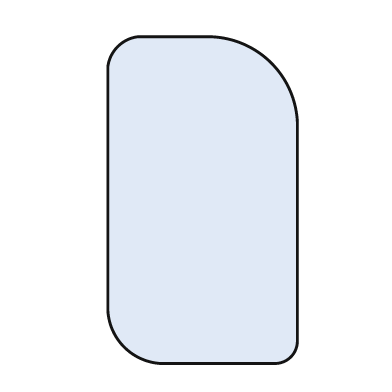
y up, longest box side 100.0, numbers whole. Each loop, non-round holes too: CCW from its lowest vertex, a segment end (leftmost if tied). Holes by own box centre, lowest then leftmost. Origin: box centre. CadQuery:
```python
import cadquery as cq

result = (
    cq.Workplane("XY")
    .moveTo(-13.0, -50.0)
    .lineTo(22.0, -50.0)
    .threePointArc((27.0, -48.0), (29.0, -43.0))
    .lineTo(29.0, 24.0)
    .threePointArc((21.0, 42.0), (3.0, 50.0))
    .lineTo(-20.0, 50.0)
    .threePointArc((-26.0, 47.0), (-29.0, 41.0))
    .lineTo(-29.0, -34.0)
    .threePointArc((-24.0, -45.0), (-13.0, -50.0))
    .close()
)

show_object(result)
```